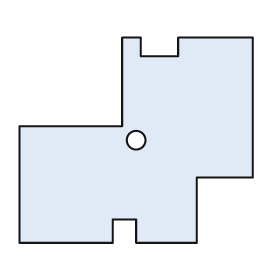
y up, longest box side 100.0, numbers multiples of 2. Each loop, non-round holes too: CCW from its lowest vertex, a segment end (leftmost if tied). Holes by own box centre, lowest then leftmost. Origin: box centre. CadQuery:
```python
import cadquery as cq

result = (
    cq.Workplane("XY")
    .moveTo(-50.0, -44.0)
    .lineTo(-10.0, -44.0)
    .lineTo(-10.0, -34.0)
    .lineTo(0.0, -34.0)
    .lineTo(0.0, -44.0)
    .lineTo(26.0, -44.0)
    .lineTo(26.0, -16.0)
    .lineTo(50.0, -16.0)
    .lineTo(50.0, 44.0)
    .lineTo(18.0, 44.0)
    .lineTo(18.0, 36.0)
    .lineTo(2.0, 36.0)
    .lineTo(2.0, 44.0)
    .lineTo(-6.0, 44.0)
    .lineTo(-6.0, 6.0)
    .lineTo(-50.0, 6.0)
    .close()
    .moveTo(0.0, 0.0)
    .circle(4.0)
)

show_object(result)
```